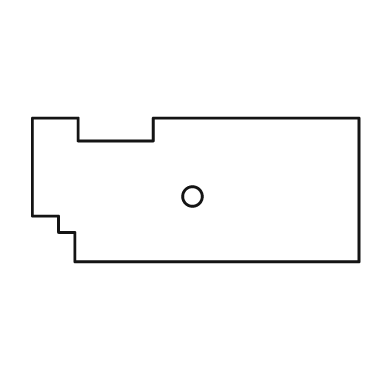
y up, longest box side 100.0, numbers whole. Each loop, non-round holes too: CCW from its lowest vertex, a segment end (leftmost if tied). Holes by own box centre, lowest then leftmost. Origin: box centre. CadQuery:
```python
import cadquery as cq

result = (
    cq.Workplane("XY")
    .moveTo(-37.0, -22.0)
    .lineTo(50.0, -22.0)
    .lineTo(50.0, 22.0)
    .lineTo(-13.0, 22.0)
    .lineTo(-13.0, 15.0)
    .lineTo(-36.0, 15.0)
    .lineTo(-36.0, 22.0)
    .lineTo(-50.0, 22.0)
    .lineTo(-50.0, -8.0)
    .lineTo(-42.0, -8.0)
    .lineTo(-42.0, -13.0)
    .lineTo(-37.0, -13.0)
    .close()
    .moveTo(-1.0, -2.0)
    .circle(3.0)
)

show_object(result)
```